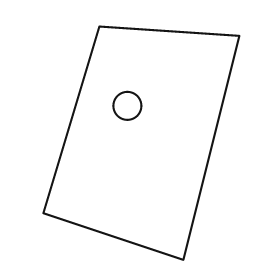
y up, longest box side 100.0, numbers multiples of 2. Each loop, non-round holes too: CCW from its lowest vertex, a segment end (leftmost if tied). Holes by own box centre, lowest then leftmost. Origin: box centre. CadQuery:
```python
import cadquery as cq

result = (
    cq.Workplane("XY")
    .moveTo(18.0, -50.0)
    .lineTo(42.0, 46.0)
    .lineTo(-18.0, 50.0)
    .lineTo(-42.0, -30.0)
    .close()
    .moveTo(-6.0, 16.0)
    .circle(6.0)
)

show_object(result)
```